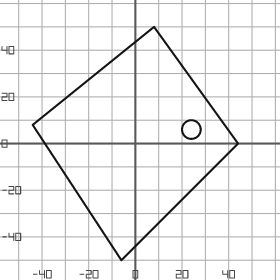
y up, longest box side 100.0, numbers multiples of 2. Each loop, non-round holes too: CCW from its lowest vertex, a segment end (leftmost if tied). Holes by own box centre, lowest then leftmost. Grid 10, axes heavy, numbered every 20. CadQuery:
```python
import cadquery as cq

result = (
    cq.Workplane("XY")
    .moveTo(-6.0, -50.0)
    .lineTo(44.0, 0.0)
    .lineTo(8.0, 50.0)
    .lineTo(-44.0, 8.0)
    .close()
    .moveTo(24.0, 6.0)
    .circle(4.0)
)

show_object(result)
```